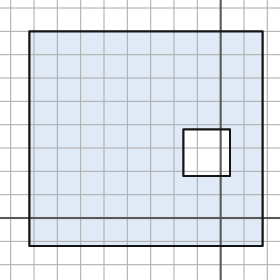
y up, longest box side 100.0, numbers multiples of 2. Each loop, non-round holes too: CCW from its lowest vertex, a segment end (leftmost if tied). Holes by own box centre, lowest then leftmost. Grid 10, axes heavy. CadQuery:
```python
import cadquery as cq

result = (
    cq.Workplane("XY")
    .moveTo(-82.0, -12.0)
    .lineTo(18.0, -12.0)
    .lineTo(18.0, 80.0)
    .lineTo(-82.0, 80.0)
    .close()
    .moveTo(-16.0, 18.0)
    .lineTo(4.0, 18.0)
    .lineTo(4.0, 38.0)
    .lineTo(-16.0, 38.0)
    .close()
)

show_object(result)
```